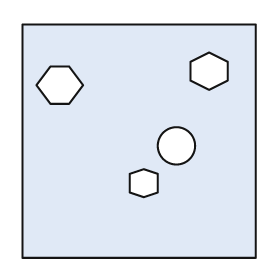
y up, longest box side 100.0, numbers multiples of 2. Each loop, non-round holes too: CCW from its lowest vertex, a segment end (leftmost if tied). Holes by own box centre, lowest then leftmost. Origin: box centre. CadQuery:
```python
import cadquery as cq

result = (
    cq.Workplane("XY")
    .moveTo(-50.0, -50.0)
    .lineTo(50.0, -50.0)
    .lineTo(50.0, 50.0)
    .lineTo(-50.0, 50.0)
    .close()
    .moveTo(2.0, -24.0)
    .lineTo(8.0, -22.0)
    .lineTo(8.0, -14.0)
    .lineTo(2.0, -12.0)
    .lineTo(-4.0, -14.0)
    .lineTo(-4.0, -22.0)
    .close()
    .moveTo(16.0, -2.0)
    .circle(8.0)
    .moveTo(-38.0, 16.0)
    .lineTo(-30.0, 16.0)
    .lineTo(-24.0, 24.0)
    .lineTo(-30.0, 32.0)
    .lineTo(-38.0, 32.0)
    .lineTo(-44.0, 24.0)
    .close()
    .moveTo(30.0, 22.0)
    .lineTo(38.0, 26.0)
    .lineTo(38.0, 34.0)
    .lineTo(30.0, 38.0)
    .lineTo(22.0, 34.0)
    .lineTo(22.0, 26.0)
    .close()
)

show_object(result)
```